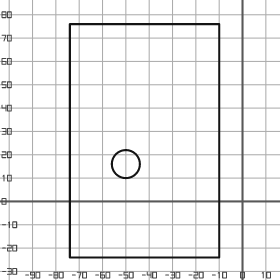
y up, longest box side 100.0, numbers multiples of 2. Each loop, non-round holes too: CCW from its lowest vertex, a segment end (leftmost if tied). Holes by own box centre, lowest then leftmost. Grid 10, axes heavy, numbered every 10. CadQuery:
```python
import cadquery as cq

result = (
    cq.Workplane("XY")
    .moveTo(-74.0, -24.0)
    .lineTo(-10.0, -24.0)
    .lineTo(-10.0, 76.0)
    .lineTo(-74.0, 76.0)
    .close()
    .moveTo(-50.0, 16.0)
    .circle(6.0)
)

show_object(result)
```